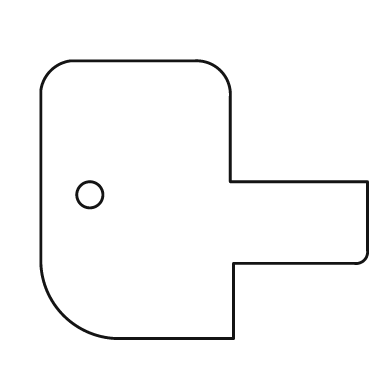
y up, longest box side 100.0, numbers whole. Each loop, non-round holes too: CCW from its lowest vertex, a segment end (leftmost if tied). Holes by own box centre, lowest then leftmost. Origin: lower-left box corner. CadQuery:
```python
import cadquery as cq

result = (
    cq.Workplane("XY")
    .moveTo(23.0, 0.0)
    .lineTo(59.0, 0.0)
    .lineTo(59.0, 23.0)
    .lineTo(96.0, 23.0)
    .threePointArc((99.0, 24.0), (100.0, 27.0))
    .lineTo(100.0, 48.0)
    .lineTo(58.0, 48.0)
    .lineTo(58.0, 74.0)
    .threePointArc((55.0, 82.0), (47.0, 85.0))
    .lineTo(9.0, 85.0)
    .threePointArc((3.0, 82.0), (0.0, 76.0))
    .lineTo(0.0, 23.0)
    .threePointArc((7.0, 7.0), (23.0, 0.0))
    .close()
    .moveTo(15.0, 44.0)
    .circle(4.0)
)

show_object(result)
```